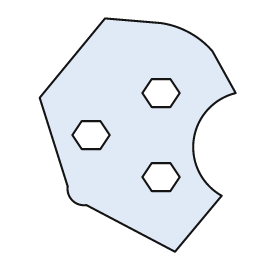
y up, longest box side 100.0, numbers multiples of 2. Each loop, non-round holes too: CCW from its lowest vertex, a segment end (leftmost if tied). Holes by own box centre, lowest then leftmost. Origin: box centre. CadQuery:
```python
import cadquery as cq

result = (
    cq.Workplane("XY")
    .moveTo(16.0, -50.0)
    .lineTo(36.0, -26.0)
    .threePointArc((24.0, -2.0), (42.0, 18.0))
    .lineTo(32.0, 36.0)
    .threePointArc((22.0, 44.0), (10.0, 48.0))
    .lineTo(-14.0, 50.0)
    .lineTo(-42.0, 16.0)
    .lineTo(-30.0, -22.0)
    .threePointArc((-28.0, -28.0), (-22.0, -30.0))
    .close()
    .moveTo(6.0, -24.0)
    .lineTo(14.0, -24.0)
    .lineTo(18.0, -18.0)
    .lineTo(14.0, -12.0)
    .lineTo(6.0, -12.0)
    .lineTo(2.0, -18.0)
    .close()
    .moveTo(-24.0, -6.0)
    .lineTo(-16.0, -6.0)
    .lineTo(-12.0, 0.0)
    .lineTo(-16.0, 6.0)
    .lineTo(-24.0, 6.0)
    .lineTo(-28.0, 0.0)
    .close()
    .moveTo(6.0, 12.0)
    .lineTo(14.0, 12.0)
    .lineTo(18.0, 18.0)
    .lineTo(14.0, 24.0)
    .lineTo(6.0, 24.0)
    .lineTo(2.0, 18.0)
    .close()
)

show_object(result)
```